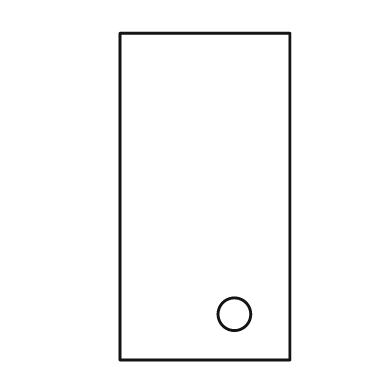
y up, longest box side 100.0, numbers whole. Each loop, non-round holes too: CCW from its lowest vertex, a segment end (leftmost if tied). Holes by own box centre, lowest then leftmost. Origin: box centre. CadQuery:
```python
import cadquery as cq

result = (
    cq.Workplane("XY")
    .moveTo(-26.0, -50.0)
    .lineTo(26.0, -50.0)
    .lineTo(26.0, 50.0)
    .lineTo(-26.0, 50.0)
    .close()
    .moveTo(9.0, -36.0)
    .circle(5.0)
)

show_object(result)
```